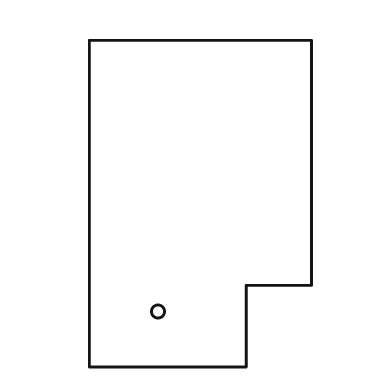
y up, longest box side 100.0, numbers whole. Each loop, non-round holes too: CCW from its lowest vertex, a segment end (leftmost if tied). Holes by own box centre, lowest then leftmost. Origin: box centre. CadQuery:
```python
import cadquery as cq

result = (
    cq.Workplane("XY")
    .moveTo(-34.0, -50.0)
    .lineTo(14.0, -50.0)
    .lineTo(14.0, -25.0)
    .lineTo(34.0, -25.0)
    .lineTo(34.0, 50.0)
    .lineTo(-34.0, 50.0)
    .close()
    .moveTo(-13.0, -33.0)
    .circle(2.0)
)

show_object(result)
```